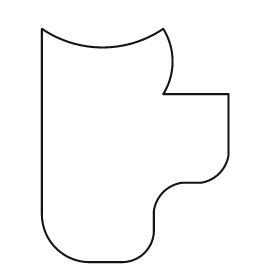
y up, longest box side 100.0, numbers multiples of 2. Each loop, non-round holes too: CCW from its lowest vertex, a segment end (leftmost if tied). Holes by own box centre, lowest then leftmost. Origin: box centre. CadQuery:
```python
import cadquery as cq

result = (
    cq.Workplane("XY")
    .moveTo(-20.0, -50.0)
    .lineTo(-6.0, -50.0)
    .threePointArc((4.0, -46.0), (8.0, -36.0))
    .lineTo(8.0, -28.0)
    .threePointArc((12.0, -20.0), (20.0, -16.0))
    .lineTo(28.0, -16.0)
    .threePointArc((36.0, -12.0), (40.0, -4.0))
    .lineTo(40.0, 22.0)
    .lineTo(12.0, 22.0)
    .threePointArc((16.0, 36.0), (12.0, 50.0))
    .threePointArc((-14.0, 42.0), (-40.0, 50.0))
    .lineTo(-40.0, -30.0)
    .threePointArc((-34.0, -44.0), (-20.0, -50.0))
    .close()
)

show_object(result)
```